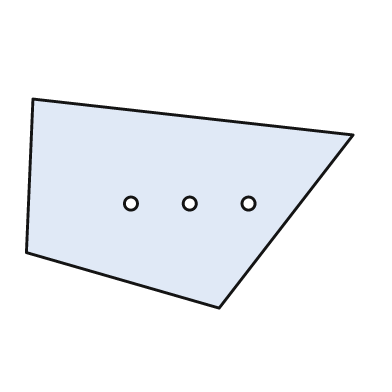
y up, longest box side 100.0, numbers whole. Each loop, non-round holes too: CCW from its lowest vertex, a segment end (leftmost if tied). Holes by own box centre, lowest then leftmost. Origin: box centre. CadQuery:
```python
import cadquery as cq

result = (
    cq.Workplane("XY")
    .moveTo(9.0, -32.0)
    .lineTo(50.0, 21.0)
    .lineTo(-48.0, 32.0)
    .lineTo(-50.0, -15.0)
    .close()
    .moveTo(-18.0, 0.0)
    .circle(2.0)
    .moveTo(0.0, 0.0)
    .circle(2.0)
    .moveTo(18.0, 0.0)
    .circle(2.0)
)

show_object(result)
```